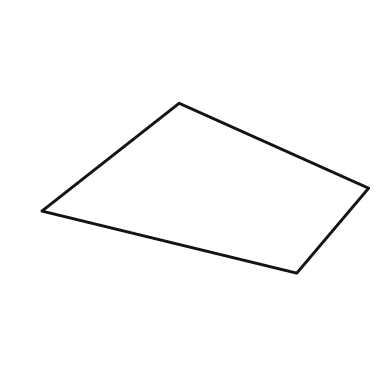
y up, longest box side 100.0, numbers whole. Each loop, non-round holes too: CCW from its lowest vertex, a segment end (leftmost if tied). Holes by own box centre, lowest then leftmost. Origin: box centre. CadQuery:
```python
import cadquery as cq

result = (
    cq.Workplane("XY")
    .moveTo(28.0, -26.0)
    .lineTo(50.0, 0.0)
    .lineTo(-8.0, 26.0)
    .lineTo(-50.0, -7.0)
    .close()
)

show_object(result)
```